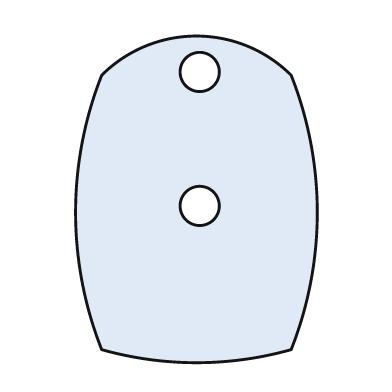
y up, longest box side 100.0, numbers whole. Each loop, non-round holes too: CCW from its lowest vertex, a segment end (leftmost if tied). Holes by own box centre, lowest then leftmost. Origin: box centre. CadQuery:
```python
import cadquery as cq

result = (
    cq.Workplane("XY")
    .moveTo(-29.0, -46.0)
    .threePointArc((0.0, -50.0), (29.0, -46.0))
    .threePointArc((37.0, -4.0), (29.0, 38.0))
    .threePointArc((0.0, 50.0), (-29.0, 38.0))
    .threePointArc((-37.0, -4.0), (-29.0, -46.0))
    .close()
    .moveTo(1.0, -2.0)
    .circle(6.0)
    .moveTo(1.0, 39.0)
    .circle(6.0)
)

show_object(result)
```